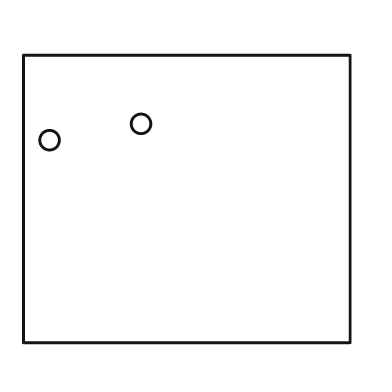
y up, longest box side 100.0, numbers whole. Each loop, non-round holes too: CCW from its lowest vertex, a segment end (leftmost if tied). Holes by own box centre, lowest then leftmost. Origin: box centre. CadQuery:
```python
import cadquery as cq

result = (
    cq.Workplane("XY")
    .moveTo(-50.0, -44.0)
    .lineTo(50.0, -44.0)
    .lineTo(50.0, 44.0)
    .lineTo(-50.0, 44.0)
    .close()
    .moveTo(-42.0, 18.0)
    .circle(3.0)
    .moveTo(-14.0, 23.0)
    .circle(3.0)
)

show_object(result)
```